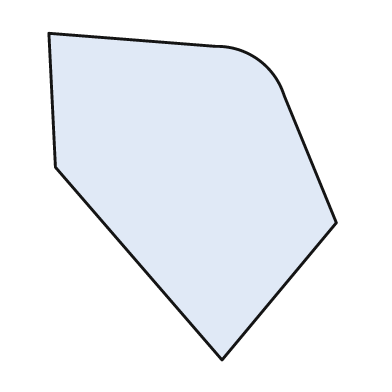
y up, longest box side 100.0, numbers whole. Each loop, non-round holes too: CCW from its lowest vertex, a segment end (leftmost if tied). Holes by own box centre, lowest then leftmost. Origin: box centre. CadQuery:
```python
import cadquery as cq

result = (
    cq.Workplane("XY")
    .moveTo(9.0, -50.0)
    .lineTo(44.0, -8.0)
    .lineTo(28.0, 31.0)
    .threePointArc((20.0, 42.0), (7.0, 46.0))
    .lineTo(-44.0, 50.0)
    .lineTo(-42.0, 9.0)
    .close()
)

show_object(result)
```